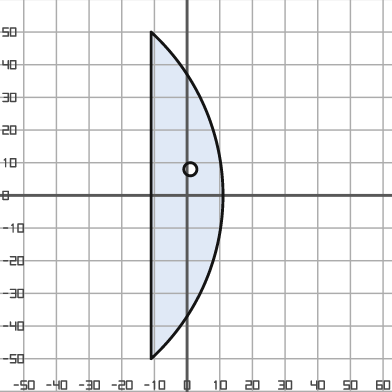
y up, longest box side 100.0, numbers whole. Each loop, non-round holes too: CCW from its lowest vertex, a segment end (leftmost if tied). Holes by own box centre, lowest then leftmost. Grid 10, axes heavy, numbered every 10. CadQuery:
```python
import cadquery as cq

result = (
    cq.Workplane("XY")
    .moveTo(-11.0, -50.0)
    .threePointArc((11.0, 0.0), (-11.0, 50.0))
    .close()
    .moveTo(1.0, 8.0)
    .circle(2.0)
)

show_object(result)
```